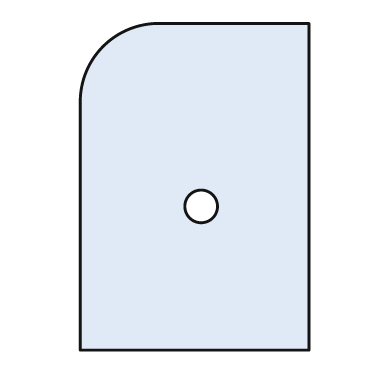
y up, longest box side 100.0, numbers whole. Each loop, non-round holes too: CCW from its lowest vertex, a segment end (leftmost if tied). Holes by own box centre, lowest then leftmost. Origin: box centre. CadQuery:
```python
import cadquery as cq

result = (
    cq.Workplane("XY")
    .moveTo(-35.0, -50.0)
    .lineTo(35.0, -50.0)
    .lineTo(35.0, 50.0)
    .lineTo(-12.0, 50.0)
    .threePointArc((-28.0, 43.0), (-35.0, 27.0))
    .close()
    .moveTo(2.0, -6.0)
    .circle(5.0)
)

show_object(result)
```